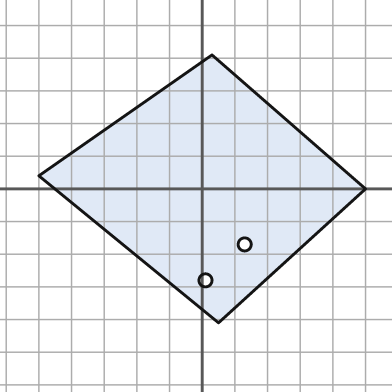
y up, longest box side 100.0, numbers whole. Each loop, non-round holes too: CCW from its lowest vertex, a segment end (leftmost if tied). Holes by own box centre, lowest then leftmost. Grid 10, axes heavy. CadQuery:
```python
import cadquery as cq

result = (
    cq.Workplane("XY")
    .moveTo(5.0, -41.0)
    .lineTo(50.0, 0.0)
    .lineTo(3.0, 41.0)
    .lineTo(-50.0, 4.0)
    .close()
    .moveTo(1.0, -28.0)
    .circle(2.0)
    .moveTo(13.0, -17.0)
    .circle(2.0)
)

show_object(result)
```